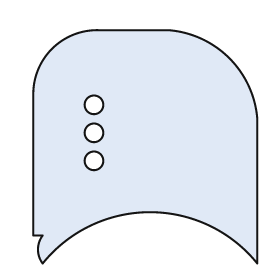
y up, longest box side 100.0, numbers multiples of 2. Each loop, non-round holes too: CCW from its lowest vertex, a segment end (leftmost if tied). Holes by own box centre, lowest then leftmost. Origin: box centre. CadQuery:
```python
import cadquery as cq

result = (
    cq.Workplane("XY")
    .moveTo(-44.0, -50.0)
    .threePointArc((2.0, -28.0), (48.0, -50.0))
    .lineTo(48.0, 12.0)
    .threePointArc((36.0, 38.0), (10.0, 50.0))
    .lineTo(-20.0, 50.0)
    .threePointArc((-40.0, 42.0), (-48.0, 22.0))
    .lineTo(-48.0, -38.0)
    .lineTo(-44.0, -38.0)
    .threePointArc((-46.0, -44.0), (-44.0, -50.0))
    .close()
    .moveTo(-22.0, -6.0)
    .circle(4.0)
    .moveTo(-22.0, 6.0)
    .circle(4.0)
    .moveTo(-22.0, 18.0)
    .circle(4.0)
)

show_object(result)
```